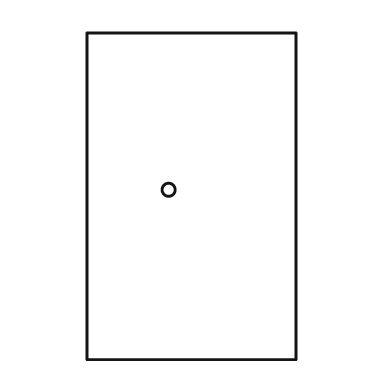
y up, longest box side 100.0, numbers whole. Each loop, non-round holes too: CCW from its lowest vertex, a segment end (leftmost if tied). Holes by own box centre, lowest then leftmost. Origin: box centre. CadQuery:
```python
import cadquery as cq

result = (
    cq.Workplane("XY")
    .moveTo(-32.0, -50.0)
    .lineTo(32.0, -50.0)
    .lineTo(32.0, 50.0)
    .lineTo(-32.0, 50.0)
    .close()
    .moveTo(-7.0, 2.0)
    .circle(2.0)
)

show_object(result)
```